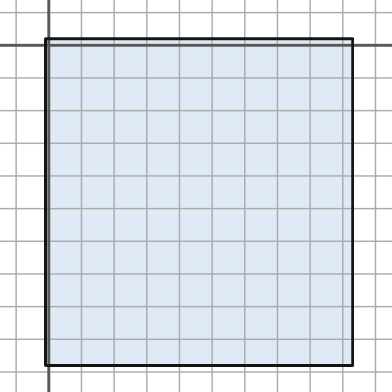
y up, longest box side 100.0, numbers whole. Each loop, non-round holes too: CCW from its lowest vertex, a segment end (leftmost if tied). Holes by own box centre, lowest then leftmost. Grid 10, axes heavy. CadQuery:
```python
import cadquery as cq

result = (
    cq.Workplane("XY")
    .moveTo(-1.0, -98.0)
    .lineTo(93.0, -98.0)
    .lineTo(93.0, 2.0)
    .lineTo(-1.0, 2.0)
    .close()
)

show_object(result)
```